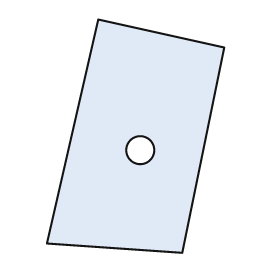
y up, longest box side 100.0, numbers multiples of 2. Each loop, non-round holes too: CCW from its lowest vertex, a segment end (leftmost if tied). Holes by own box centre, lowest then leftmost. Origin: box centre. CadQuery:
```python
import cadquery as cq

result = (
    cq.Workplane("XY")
    .moveTo(20.0, -50.0)
    .lineTo(38.0, 38.0)
    .lineTo(-16.0, 50.0)
    .lineTo(-38.0, -46.0)
    .close()
    .moveTo(2.0, -6.0)
    .circle(6.0)
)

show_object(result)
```